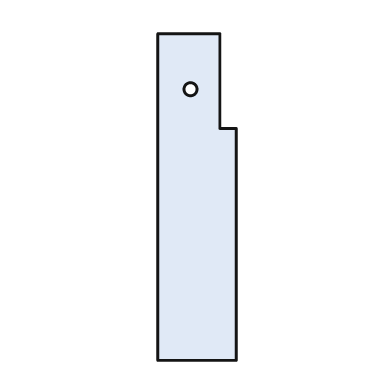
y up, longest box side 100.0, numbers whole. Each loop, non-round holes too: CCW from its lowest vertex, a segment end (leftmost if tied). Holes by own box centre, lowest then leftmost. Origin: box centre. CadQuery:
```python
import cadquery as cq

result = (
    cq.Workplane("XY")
    .moveTo(-12.0, -50.0)
    .lineTo(12.0, -50.0)
    .lineTo(12.0, 21.0)
    .lineTo(7.0, 21.0)
    .lineTo(7.0, 50.0)
    .lineTo(-12.0, 50.0)
    .close()
    .moveTo(-2.0, 33.0)
    .circle(2.0)
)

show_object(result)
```